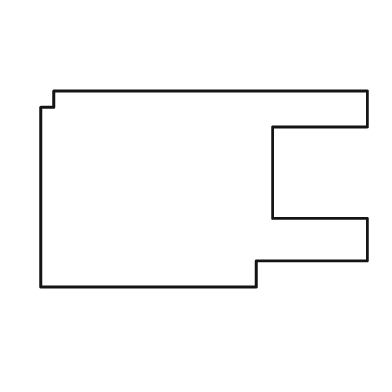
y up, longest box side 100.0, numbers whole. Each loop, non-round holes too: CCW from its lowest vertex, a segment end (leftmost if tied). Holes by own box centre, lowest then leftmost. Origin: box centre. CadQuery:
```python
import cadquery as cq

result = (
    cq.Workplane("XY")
    .moveTo(-50.0, -30.0)
    .lineTo(16.0, -30.0)
    .lineTo(16.0, -22.0)
    .lineTo(50.0, -22.0)
    .lineTo(50.0, -9.0)
    .lineTo(21.0, -9.0)
    .lineTo(21.0, 19.0)
    .lineTo(50.0, 19.0)
    .lineTo(50.0, 30.0)
    .lineTo(-46.0, 30.0)
    .lineTo(-46.0, 25.0)
    .lineTo(-50.0, 25.0)
    .close()
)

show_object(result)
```